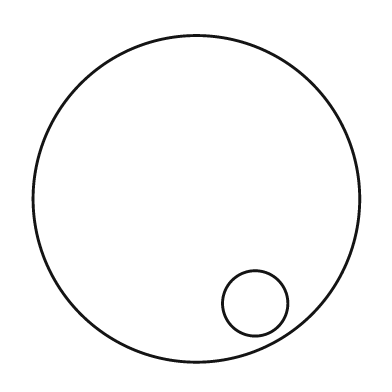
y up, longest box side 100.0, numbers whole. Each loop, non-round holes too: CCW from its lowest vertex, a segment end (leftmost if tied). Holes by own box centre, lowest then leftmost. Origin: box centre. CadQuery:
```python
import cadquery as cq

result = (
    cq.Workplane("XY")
    .moveTo(0.0, 0.0)
    .circle(50.0)
    .moveTo(18.0, -32.0)
    .circle(10.0)
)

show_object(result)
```